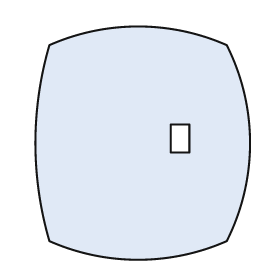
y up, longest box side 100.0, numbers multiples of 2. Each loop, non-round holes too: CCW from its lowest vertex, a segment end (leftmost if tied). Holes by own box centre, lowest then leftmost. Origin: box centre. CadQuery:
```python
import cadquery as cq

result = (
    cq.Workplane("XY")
    .moveTo(-40.0, -42.0)
    .threePointArc((-2.0, -50.0), (36.0, -42.0))
    .threePointArc((46.0, 0.0), (36.0, 42.0))
    .threePointArc((-2.0, 50.0), (-40.0, 42.0))
    .threePointArc((-46.0, 0.0), (-40.0, -42.0))
    .close()
    .moveTo(12.0, -4.0)
    .lineTo(20.0, -4.0)
    .lineTo(20.0, 8.0)
    .lineTo(12.0, 8.0)
    .close()
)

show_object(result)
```